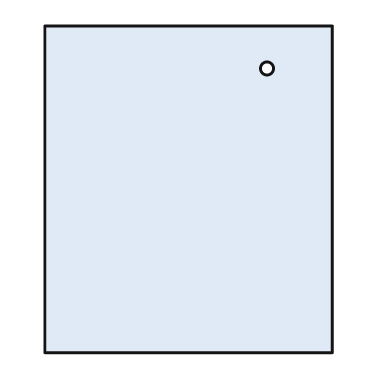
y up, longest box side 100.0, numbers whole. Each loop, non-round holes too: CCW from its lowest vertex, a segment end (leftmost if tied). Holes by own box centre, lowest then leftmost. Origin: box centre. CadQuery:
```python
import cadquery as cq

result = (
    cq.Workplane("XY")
    .moveTo(-44.0, -50.0)
    .lineTo(44.0, -50.0)
    .lineTo(44.0, 50.0)
    .lineTo(-44.0, 50.0)
    .close()
    .moveTo(24.0, 37.0)
    .circle(2.0)
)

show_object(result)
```